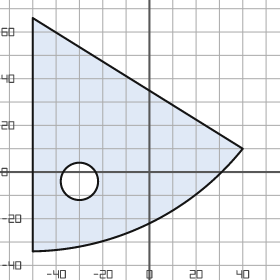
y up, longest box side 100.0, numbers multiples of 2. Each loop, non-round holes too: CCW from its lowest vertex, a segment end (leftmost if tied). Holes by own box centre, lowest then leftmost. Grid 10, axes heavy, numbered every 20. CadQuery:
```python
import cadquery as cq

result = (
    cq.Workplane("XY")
    .moveTo(-50.0, -34.0)
    .threePointArc((0.0, -22.0), (40.0, 10.0))
    .lineTo(-50.0, 66.0)
    .close()
    .moveTo(-30.0, -4.0)
    .circle(8.0)
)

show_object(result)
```